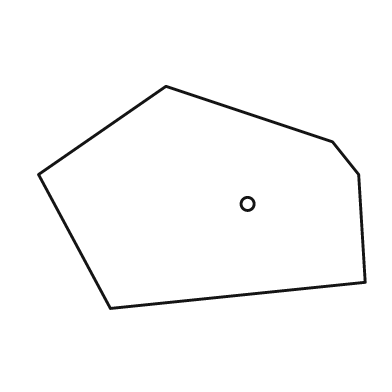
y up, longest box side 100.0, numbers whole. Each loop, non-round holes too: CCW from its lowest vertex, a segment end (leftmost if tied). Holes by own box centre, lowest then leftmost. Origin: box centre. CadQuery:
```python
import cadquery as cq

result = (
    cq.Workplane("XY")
    .moveTo(-28.0, -34.0)
    .lineTo(50.0, -26.0)
    .lineTo(48.0, 7.0)
    .lineTo(40.0, 17.0)
    .lineTo(-11.0, 34.0)
    .lineTo(-50.0, 7.0)
    .close()
    .moveTo(14.0, -2.0)
    .circle(2.0)
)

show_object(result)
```